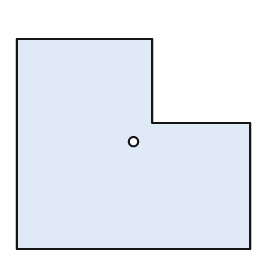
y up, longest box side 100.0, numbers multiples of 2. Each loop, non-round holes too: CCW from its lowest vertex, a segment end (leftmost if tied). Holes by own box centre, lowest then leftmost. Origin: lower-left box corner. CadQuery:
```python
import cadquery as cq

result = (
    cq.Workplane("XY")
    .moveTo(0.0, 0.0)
    .lineTo(100.0, 0.0)
    .lineTo(100.0, 54.0)
    .lineTo(58.0, 54.0)
    .lineTo(58.0, 90.0)
    .lineTo(0.0, 90.0)
    .close()
    .moveTo(50.0, 46.0)
    .circle(2.0)
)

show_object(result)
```